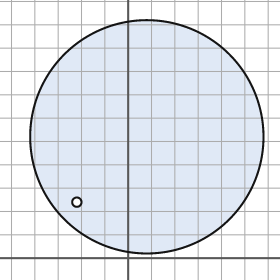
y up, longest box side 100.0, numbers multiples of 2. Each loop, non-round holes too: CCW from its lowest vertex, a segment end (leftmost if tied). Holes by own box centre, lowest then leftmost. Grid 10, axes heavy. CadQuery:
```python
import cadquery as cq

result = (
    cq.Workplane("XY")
    .moveTo(8.0, 52.0)
    .circle(50.0)
    .moveTo(-22.0, 24.0)
    .circle(2.0)
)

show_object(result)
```